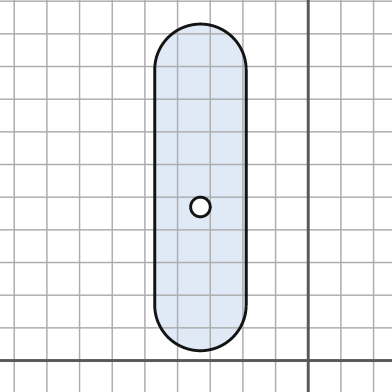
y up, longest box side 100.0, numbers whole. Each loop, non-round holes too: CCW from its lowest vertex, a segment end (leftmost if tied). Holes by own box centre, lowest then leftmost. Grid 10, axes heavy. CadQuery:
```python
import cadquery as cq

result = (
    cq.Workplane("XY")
    .moveTo(-47.0, 17.0)
    .threePointArc((-33.0, 3.0), (-19.0, 17.0))
    .lineTo(-19.0, 89.0)
    .threePointArc((-33.0, 103.0), (-47.0, 89.0))
    .close()
    .moveTo(-33.0, 47.0)
    .circle(3.0)
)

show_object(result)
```